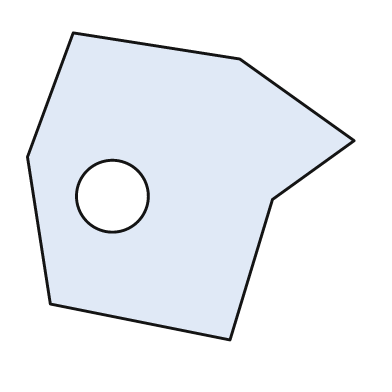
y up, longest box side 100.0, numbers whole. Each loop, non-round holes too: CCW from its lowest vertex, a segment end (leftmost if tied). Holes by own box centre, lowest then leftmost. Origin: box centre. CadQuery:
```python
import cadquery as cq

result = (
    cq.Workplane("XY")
    .moveTo(12.0, -47.0)
    .lineTo(25.0, -4.0)
    .lineTo(50.0, 14.0)
    .lineTo(15.0, 39.0)
    .lineTo(-36.0, 47.0)
    .lineTo(-50.0, 9.0)
    .lineTo(-43.0, -36.0)
    .close()
    .moveTo(-24.0, -3.0)
    .circle(11.0)
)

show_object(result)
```